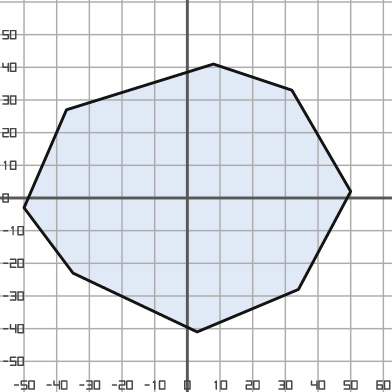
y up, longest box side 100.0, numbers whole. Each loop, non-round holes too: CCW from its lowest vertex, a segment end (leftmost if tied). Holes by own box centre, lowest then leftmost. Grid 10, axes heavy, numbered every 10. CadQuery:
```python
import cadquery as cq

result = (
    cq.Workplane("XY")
    .moveTo(3.0, -41.0)
    .lineTo(34.0, -28.0)
    .lineTo(50.0, 2.0)
    .lineTo(32.0, 33.0)
    .lineTo(8.0, 41.0)
    .lineTo(-37.0, 27.0)
    .lineTo(-50.0, -3.0)
    .lineTo(-35.0, -23.0)
    .close()
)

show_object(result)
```